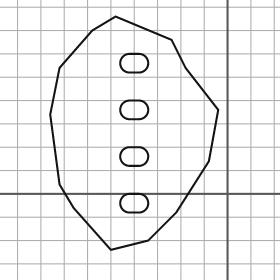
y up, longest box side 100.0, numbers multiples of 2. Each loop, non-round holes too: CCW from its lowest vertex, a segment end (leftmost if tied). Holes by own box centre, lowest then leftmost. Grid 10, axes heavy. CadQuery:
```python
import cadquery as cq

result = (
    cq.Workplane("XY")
    .moveTo(-50.0, -24.0)
    .lineTo(-34.0, -20.0)
    .lineTo(-22.0, -8.0)
    .lineTo(-8.0, 14.0)
    .lineTo(-4.0, 36.0)
    .lineTo(-18.0, 54.0)
    .lineTo(-24.0, 66.0)
    .lineTo(-48.0, 76.0)
    .lineTo(-58.0, 70.0)
    .lineTo(-72.0, 54.0)
    .lineTo(-76.0, 34.0)
    .lineTo(-72.0, 4.0)
    .lineTo(-66.0, -6.0)
    .close()
    .moveTo(-42.0, -8.0)
    .lineTo(-38.0, -8.0)
    .threePointArc((-34.0, -4.0), (-38.0, 0.0))
    .lineTo(-42.0, 0.0)
    .threePointArc((-46.0, -4.0), (-42.0, -8.0))
    .close()
    .moveTo(-42.0, 12.0)
    .lineTo(-38.0, 12.0)
    .threePointArc((-34.0, 16.0), (-38.0, 20.0))
    .lineTo(-42.0, 20.0)
    .threePointArc((-46.0, 16.0), (-42.0, 12.0))
    .close()
    .moveTo(-42.0, 32.0)
    .lineTo(-38.0, 32.0)
    .threePointArc((-34.0, 36.0), (-38.0, 40.0))
    .lineTo(-42.0, 40.0)
    .threePointArc((-46.0, 36.0), (-42.0, 32.0))
    .close()
    .moveTo(-42.0, 52.0)
    .lineTo(-38.0, 52.0)
    .threePointArc((-34.0, 56.0), (-38.0, 60.0))
    .lineTo(-42.0, 60.0)
    .threePointArc((-46.0, 56.0), (-42.0, 52.0))
    .close()
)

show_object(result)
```